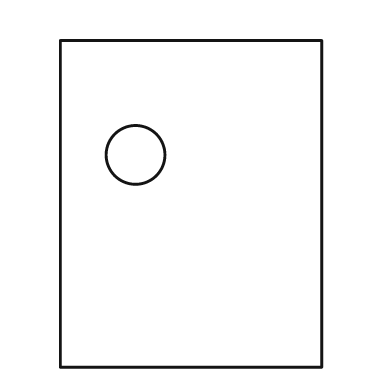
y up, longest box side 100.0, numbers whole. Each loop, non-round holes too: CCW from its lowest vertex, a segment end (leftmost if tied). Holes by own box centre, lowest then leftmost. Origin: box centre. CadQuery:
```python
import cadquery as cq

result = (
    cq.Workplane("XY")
    .moveTo(-40.0, -50.0)
    .lineTo(40.0, -50.0)
    .lineTo(40.0, 50.0)
    .lineTo(-40.0, 50.0)
    .close()
    .moveTo(-17.0, 15.0)
    .circle(9.0)
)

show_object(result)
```